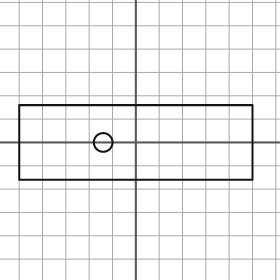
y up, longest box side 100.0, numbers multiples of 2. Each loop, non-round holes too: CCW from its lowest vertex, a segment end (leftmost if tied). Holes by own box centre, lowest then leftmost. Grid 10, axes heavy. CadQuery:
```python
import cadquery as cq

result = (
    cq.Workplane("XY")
    .moveTo(-50.0, -16.0)
    .lineTo(50.0, -16.0)
    .lineTo(50.0, 16.0)
    .lineTo(-50.0, 16.0)
    .close()
    .moveTo(-14.0, 0.0)
    .circle(4.0)
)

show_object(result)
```